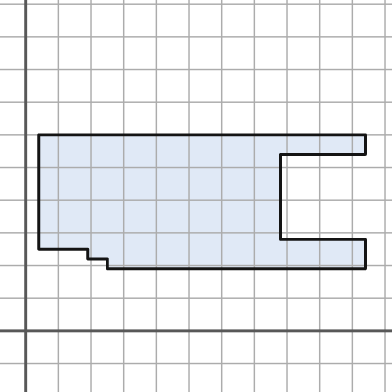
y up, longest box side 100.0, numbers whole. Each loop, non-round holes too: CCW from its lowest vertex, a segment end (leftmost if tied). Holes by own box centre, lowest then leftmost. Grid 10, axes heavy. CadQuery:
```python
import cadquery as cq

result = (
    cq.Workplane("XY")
    .moveTo(25.0, 19.0)
    .lineTo(104.0, 19.0)
    .lineTo(104.0, 28.0)
    .lineTo(78.0, 28.0)
    .lineTo(78.0, 54.0)
    .lineTo(104.0, 54.0)
    .lineTo(104.0, 60.0)
    .lineTo(4.0, 60.0)
    .lineTo(4.0, 25.0)
    .lineTo(19.0, 25.0)
    .lineTo(19.0, 22.0)
    .lineTo(25.0, 22.0)
    .close()
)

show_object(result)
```